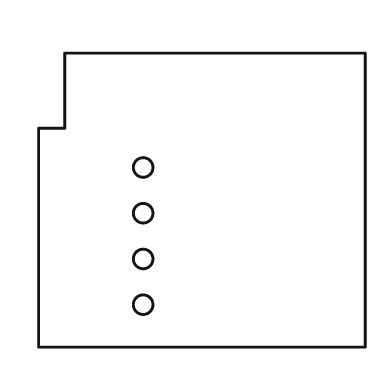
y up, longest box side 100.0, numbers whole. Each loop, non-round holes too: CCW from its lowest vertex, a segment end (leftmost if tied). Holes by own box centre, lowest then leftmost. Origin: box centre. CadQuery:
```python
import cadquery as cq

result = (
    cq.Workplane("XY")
    .moveTo(-50.0, -45.0)
    .lineTo(50.0, -45.0)
    .lineTo(50.0, 45.0)
    .lineTo(-42.0, 45.0)
    .lineTo(-42.0, 22.0)
    .lineTo(-50.0, 22.0)
    .close()
    .moveTo(-18.0, -32.0)
    .circle(3.0)
    .moveTo(-18.0, -18.0)
    .circle(3.0)
    .moveTo(-18.0, -4.0)
    .circle(3.0)
    .moveTo(-18.0, 10.0)
    .circle(3.0)
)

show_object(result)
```